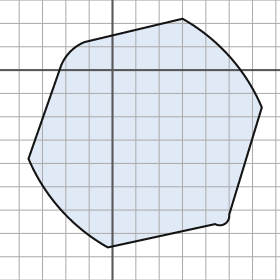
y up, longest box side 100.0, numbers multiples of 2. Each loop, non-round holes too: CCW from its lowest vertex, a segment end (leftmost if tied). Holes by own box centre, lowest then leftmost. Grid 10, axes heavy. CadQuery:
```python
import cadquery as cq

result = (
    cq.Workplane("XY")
    .moveTo(-2.0, -76.0)
    .lineTo(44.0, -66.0)
    .threePointArc((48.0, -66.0), (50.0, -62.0))
    .lineTo(64.0, -16.0)
    .threePointArc((50.0, 6.0), (30.0, 22.0))
    .lineTo(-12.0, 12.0)
    .threePointArc((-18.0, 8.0), (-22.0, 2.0))
    .lineTo(-36.0, -38.0)
    .threePointArc((-22.0, -60.0), (-2.0, -76.0))
    .close()
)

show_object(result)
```